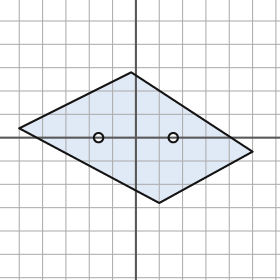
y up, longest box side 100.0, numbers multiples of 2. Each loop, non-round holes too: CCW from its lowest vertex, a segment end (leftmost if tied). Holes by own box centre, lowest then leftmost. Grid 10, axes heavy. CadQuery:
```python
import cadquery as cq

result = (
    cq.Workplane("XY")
    .moveTo(10.0, -28.0)
    .lineTo(50.0, -6.0)
    .lineTo(-2.0, 28.0)
    .lineTo(-50.0, 4.0)
    .close()
    .moveTo(-16.0, 0.0)
    .circle(2.0)
    .moveTo(16.0, 0.0)
    .circle(2.0)
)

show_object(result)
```